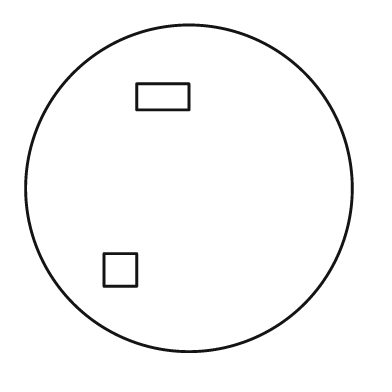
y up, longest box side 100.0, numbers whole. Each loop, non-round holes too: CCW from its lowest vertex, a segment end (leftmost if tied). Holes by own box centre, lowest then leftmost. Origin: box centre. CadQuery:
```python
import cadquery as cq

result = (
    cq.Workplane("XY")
    .moveTo(0.0, 0.0)
    .circle(50.0)
    .moveTo(-26.0, -30.0)
    .lineTo(-16.0, -30.0)
    .lineTo(-16.0, -20.0)
    .lineTo(-26.0, -20.0)
    .close()
    .moveTo(-16.0, 24.0)
    .lineTo(0.0, 24.0)
    .lineTo(0.0, 32.0)
    .lineTo(-16.0, 32.0)
    .close()
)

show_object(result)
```